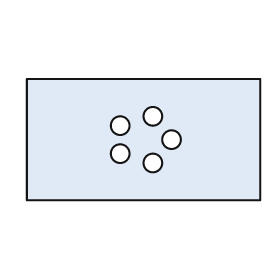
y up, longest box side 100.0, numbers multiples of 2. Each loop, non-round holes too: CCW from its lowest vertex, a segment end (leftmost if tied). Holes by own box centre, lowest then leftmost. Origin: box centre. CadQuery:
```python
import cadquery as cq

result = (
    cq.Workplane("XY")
    .moveTo(-50.0, -26.0)
    .lineTo(50.0, -26.0)
    .lineTo(50.0, 26.0)
    .lineTo(-50.0, 26.0)
    .close()
    .moveTo(4.0, -10.0)
    .circle(4.0)
    .moveTo(-10.0, -6.0)
    .circle(4.0)
    .moveTo(12.0, 0.0)
    .circle(4.0)
    .moveTo(-10.0, 6.0)
    .circle(4.0)
    .moveTo(4.0, 10.0)
    .circle(4.0)
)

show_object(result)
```